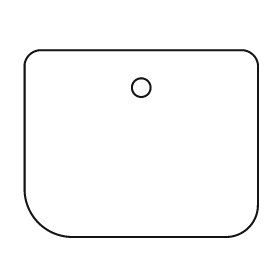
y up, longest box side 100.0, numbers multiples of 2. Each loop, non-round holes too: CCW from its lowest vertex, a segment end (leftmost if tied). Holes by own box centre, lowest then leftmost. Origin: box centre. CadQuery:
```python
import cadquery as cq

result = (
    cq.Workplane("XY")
    .moveTo(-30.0, -40.0)
    .lineTo(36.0, -40.0)
    .threePointArc((46.0, -36.0), (50.0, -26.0))
    .lineTo(50.0, 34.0)
    .threePointArc((48.0, 38.0), (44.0, 40.0))
    .lineTo(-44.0, 40.0)
    .threePointArc((-48.0, 38.0), (-50.0, 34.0))
    .lineTo(-50.0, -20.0)
    .threePointArc((-44.0, -34.0), (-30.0, -40.0))
    .close()
    .moveTo(0.0, 24.0)
    .circle(4.0)
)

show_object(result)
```